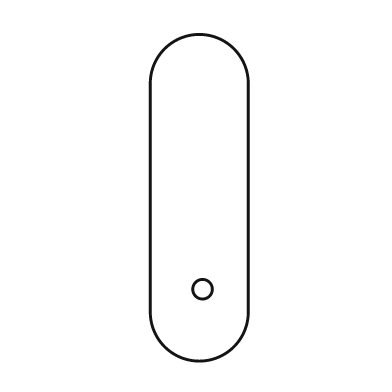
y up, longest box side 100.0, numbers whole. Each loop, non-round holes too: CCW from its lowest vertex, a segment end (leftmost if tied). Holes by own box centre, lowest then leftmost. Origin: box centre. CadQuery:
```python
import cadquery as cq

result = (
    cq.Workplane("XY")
    .moveTo(-15.0, -35.0)
    .threePointArc((0.0, -50.0), (15.0, -35.0))
    .lineTo(15.0, 35.0)
    .threePointArc((0.0, 50.0), (-15.0, 35.0))
    .close()
    .moveTo(1.0, -28.0)
    .circle(3.0)
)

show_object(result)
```